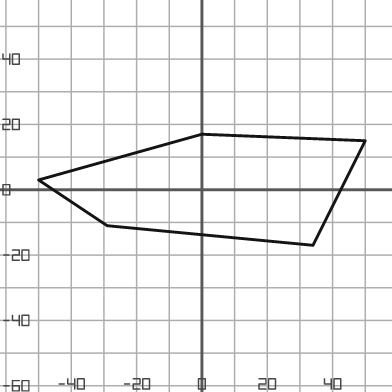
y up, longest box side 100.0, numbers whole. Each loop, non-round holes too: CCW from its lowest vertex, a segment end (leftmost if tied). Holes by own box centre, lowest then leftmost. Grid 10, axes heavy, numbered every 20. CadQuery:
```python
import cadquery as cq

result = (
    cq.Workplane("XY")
    .moveTo(34.0, -17.0)
    .lineTo(50.0, 15.0)
    .lineTo(0.0, 17.0)
    .lineTo(-50.0, 3.0)
    .lineTo(-29.0, -11.0)
    .close()
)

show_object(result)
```